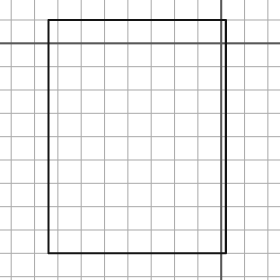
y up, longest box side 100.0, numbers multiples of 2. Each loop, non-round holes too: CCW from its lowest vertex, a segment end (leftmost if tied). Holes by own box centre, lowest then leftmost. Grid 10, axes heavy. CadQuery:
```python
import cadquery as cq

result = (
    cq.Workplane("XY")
    .moveTo(-74.0, -90.0)
    .lineTo(2.0, -90.0)
    .lineTo(2.0, 10.0)
    .lineTo(-74.0, 10.0)
    .close()
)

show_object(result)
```